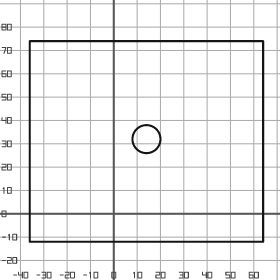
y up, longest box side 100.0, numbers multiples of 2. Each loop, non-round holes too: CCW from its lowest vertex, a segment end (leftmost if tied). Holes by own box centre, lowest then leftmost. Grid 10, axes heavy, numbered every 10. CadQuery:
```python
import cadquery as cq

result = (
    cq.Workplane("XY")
    .moveTo(-36.0, -12.0)
    .lineTo(64.0, -12.0)
    .lineTo(64.0, 74.0)
    .lineTo(-36.0, 74.0)
    .close()
    .moveTo(14.0, 32.0)
    .circle(6.0)
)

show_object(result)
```